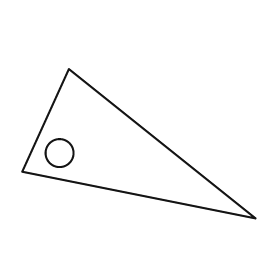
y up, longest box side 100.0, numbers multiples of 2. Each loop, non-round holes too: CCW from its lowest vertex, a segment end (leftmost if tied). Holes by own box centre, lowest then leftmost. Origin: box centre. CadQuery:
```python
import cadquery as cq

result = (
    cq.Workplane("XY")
    .moveTo(50.0, -32.0)
    .lineTo(-30.0, 32.0)
    .lineTo(-50.0, -12.0)
    .close()
    .moveTo(-34.0, -4.0)
    .circle(6.0)
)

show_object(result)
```